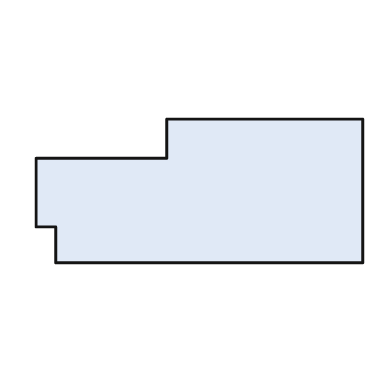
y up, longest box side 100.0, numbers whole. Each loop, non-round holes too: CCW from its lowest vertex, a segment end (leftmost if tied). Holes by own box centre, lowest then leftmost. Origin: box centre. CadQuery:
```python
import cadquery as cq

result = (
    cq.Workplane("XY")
    .moveTo(-44.0, -22.0)
    .lineTo(50.0, -22.0)
    .lineTo(50.0, 22.0)
    .lineTo(-10.0, 22.0)
    .lineTo(-10.0, 10.0)
    .lineTo(-50.0, 10.0)
    .lineTo(-50.0, -11.0)
    .lineTo(-44.0, -11.0)
    .close()
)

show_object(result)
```